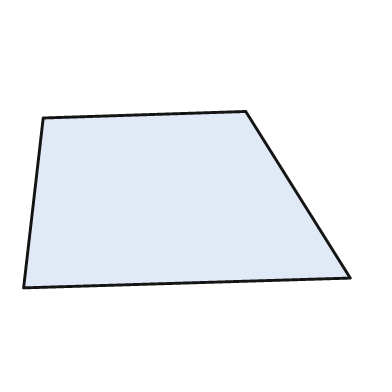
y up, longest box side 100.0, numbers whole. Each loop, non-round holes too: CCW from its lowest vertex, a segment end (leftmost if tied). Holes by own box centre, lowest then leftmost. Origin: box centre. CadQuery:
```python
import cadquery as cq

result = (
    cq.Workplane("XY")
    .moveTo(-50.0, -27.0)
    .lineTo(50.0, -24.0)
    .lineTo(18.0, 27.0)
    .lineTo(-44.0, 25.0)
    .close()
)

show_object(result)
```